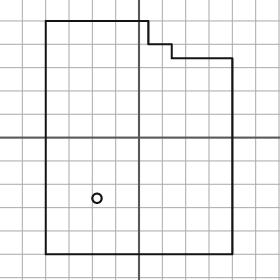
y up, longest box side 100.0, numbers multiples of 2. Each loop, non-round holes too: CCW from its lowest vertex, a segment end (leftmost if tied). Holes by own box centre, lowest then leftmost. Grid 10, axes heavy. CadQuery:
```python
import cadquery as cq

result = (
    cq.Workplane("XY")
    .moveTo(-40.0, -50.0)
    .lineTo(40.0, -50.0)
    .lineTo(40.0, 34.0)
    .lineTo(14.0, 34.0)
    .lineTo(14.0, 40.0)
    .lineTo(4.0, 40.0)
    .lineTo(4.0, 50.0)
    .lineTo(-40.0, 50.0)
    .close()
    .moveTo(-18.0, -26.0)
    .circle(2.0)
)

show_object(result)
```